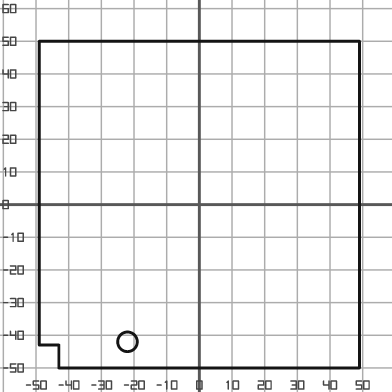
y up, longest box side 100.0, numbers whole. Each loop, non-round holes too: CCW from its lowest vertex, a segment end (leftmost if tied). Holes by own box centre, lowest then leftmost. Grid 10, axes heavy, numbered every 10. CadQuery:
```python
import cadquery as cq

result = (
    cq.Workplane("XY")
    .moveTo(-43.0, -50.0)
    .lineTo(49.0, -50.0)
    .lineTo(49.0, 50.0)
    .lineTo(-49.0, 50.0)
    .lineTo(-49.0, -43.0)
    .lineTo(-43.0, -43.0)
    .close()
    .moveTo(-22.0, -42.0)
    .circle(3.0)
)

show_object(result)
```